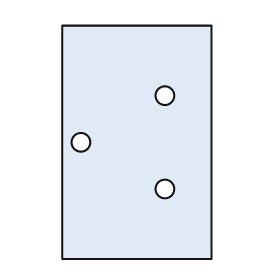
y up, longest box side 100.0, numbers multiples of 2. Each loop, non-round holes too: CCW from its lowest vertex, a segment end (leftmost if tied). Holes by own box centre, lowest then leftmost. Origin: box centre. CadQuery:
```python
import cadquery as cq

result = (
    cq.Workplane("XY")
    .moveTo(-32.0, -50.0)
    .lineTo(32.0, -50.0)
    .lineTo(32.0, 50.0)
    .lineTo(-32.0, 50.0)
    .close()
    .moveTo(12.0, -20.0)
    .circle(4.0)
    .moveTo(-24.0, 0.0)
    .circle(4.0)
    .moveTo(12.0, 20.0)
    .circle(4.0)
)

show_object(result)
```